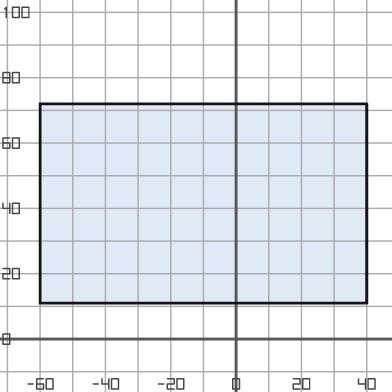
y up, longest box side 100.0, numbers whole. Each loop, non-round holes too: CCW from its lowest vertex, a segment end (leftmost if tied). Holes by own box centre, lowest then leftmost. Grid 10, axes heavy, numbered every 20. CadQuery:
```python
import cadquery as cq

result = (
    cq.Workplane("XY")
    .moveTo(-60.0, 11.0)
    .lineTo(40.0, 11.0)
    .lineTo(40.0, 72.0)
    .lineTo(-60.0, 72.0)
    .close()
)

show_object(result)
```